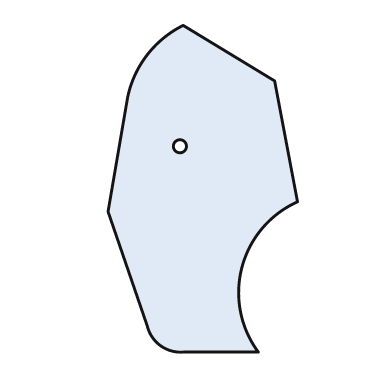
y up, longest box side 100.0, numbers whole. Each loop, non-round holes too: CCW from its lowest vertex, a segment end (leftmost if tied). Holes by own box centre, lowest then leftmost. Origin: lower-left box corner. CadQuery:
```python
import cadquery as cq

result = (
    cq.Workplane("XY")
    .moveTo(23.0, 0.0)
    .lineTo(46.0, 0.0)
    .threePointArc((41.0, 26.0), (58.0, 46.0))
    .lineTo(51.0, 83.0)
    .lineTo(23.0, 100.0)
    .threePointArc((12.0, 91.0), (6.0, 78.0))
    .lineTo(0.0, 43.0)
    .lineTo(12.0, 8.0)
    .threePointArc((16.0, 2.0), (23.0, 0.0))
    .close()
    .moveTo(22.0, 63.0)
    .circle(2.0)
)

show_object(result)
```